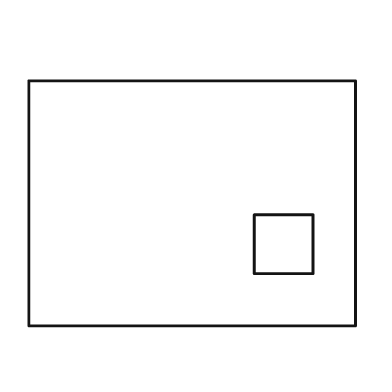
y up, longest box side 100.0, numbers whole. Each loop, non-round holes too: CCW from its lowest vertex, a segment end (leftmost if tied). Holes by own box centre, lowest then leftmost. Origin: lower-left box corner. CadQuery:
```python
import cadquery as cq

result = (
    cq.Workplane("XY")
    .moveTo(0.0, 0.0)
    .lineTo(100.0, 0.0)
    .lineTo(100.0, 75.0)
    .lineTo(0.0, 75.0)
    .close()
    .moveTo(69.0, 16.0)
    .lineTo(87.0, 16.0)
    .lineTo(87.0, 34.0)
    .lineTo(69.0, 34.0)
    .close()
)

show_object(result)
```